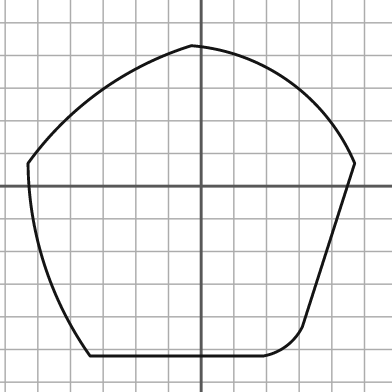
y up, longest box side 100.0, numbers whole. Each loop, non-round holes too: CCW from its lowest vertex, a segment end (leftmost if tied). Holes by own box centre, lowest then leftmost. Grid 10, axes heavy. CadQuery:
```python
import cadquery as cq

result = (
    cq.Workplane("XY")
    .moveTo(-34.0, -52.0)
    .lineTo(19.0, -52.0)
    .threePointArc((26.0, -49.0), (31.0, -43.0))
    .lineTo(47.0, 7.0)
    .threePointArc((27.0, 32.0), (-3.0, 43.0))
    .threePointArc((-31.0, 29.0), (-53.0, 7.0))
    .threePointArc((-48.0, -24.0), (-34.0, -52.0))
    .close()
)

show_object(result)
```